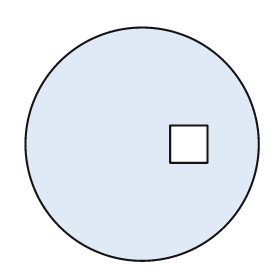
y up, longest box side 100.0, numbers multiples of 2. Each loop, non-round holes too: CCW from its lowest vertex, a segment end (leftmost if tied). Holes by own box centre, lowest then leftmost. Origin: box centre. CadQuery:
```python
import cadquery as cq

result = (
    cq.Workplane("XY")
    .moveTo(0.0, 0.0)
    .circle(50.0)
    .moveTo(12.0, -8.0)
    .lineTo(28.0, -8.0)
    .lineTo(28.0, 8.0)
    .lineTo(12.0, 8.0)
    .close()
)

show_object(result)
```